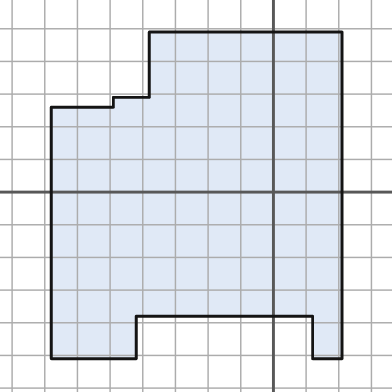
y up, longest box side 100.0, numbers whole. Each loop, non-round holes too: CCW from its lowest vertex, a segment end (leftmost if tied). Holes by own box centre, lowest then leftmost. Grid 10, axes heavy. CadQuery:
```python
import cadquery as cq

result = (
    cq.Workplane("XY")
    .moveTo(-68.0, -51.0)
    .lineTo(-42.0, -51.0)
    .lineTo(-42.0, -38.0)
    .lineTo(12.0, -38.0)
    .lineTo(12.0, -51.0)
    .lineTo(21.0, -51.0)
    .lineTo(21.0, 49.0)
    .lineTo(-38.0, 49.0)
    .lineTo(-38.0, 29.0)
    .lineTo(-49.0, 29.0)
    .lineTo(-49.0, 26.0)
    .lineTo(-68.0, 26.0)
    .close()
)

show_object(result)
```